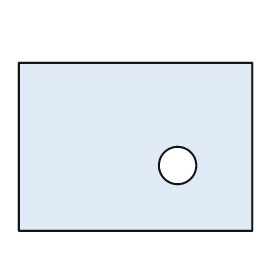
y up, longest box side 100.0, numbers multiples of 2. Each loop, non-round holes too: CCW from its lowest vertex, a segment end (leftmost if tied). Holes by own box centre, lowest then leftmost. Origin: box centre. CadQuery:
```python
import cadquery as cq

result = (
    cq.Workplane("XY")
    .moveTo(-50.0, -36.0)
    .lineTo(50.0, -36.0)
    .lineTo(50.0, 36.0)
    .lineTo(-50.0, 36.0)
    .close()
    .moveTo(18.0, -8.0)
    .circle(8.0)
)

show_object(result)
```